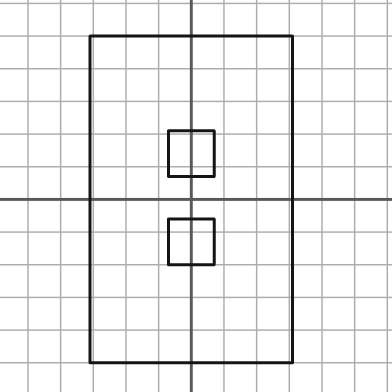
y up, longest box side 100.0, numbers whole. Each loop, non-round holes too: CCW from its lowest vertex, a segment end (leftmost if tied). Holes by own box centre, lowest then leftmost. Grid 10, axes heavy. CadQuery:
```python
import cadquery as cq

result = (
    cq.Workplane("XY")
    .moveTo(-31.0, -50.0)
    .lineTo(31.0, -50.0)
    .lineTo(31.0, 50.0)
    .lineTo(-31.0, 50.0)
    .close()
    .moveTo(-7.0, -20.0)
    .lineTo(7.0, -20.0)
    .lineTo(7.0, -6.0)
    .lineTo(-7.0, -6.0)
    .close()
    .moveTo(-7.0, 7.0)
    .lineTo(7.0, 7.0)
    .lineTo(7.0, 21.0)
    .lineTo(-7.0, 21.0)
    .close()
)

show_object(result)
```